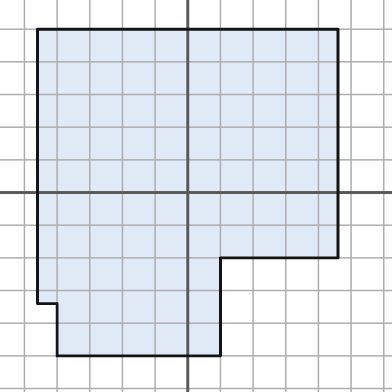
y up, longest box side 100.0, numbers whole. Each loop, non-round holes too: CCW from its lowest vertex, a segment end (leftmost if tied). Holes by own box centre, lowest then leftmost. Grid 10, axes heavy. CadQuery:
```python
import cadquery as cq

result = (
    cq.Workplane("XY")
    .moveTo(-40.0, -50.0)
    .lineTo(10.0, -50.0)
    .lineTo(10.0, -20.0)
    .lineTo(46.0, -20.0)
    .lineTo(46.0, 50.0)
    .lineTo(-46.0, 50.0)
    .lineTo(-46.0, -34.0)
    .lineTo(-40.0, -34.0)
    .close()
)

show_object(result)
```